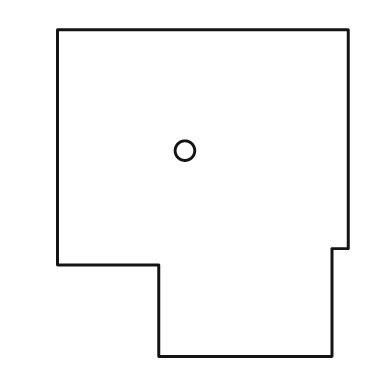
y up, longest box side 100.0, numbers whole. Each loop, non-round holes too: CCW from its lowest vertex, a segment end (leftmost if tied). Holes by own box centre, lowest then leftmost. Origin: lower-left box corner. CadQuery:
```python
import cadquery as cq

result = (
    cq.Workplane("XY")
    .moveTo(31.0, 0.0)
    .lineTo(84.0, 0.0)
    .lineTo(84.0, 33.0)
    .lineTo(89.0, 33.0)
    .lineTo(89.0, 100.0)
    .lineTo(0.0, 100.0)
    .lineTo(0.0, 28.0)
    .lineTo(31.0, 28.0)
    .close()
    .moveTo(39.0, 63.0)
    .circle(3.0)
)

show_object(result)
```